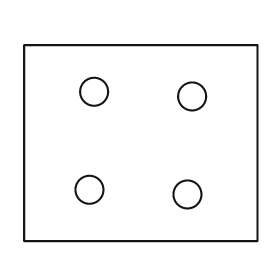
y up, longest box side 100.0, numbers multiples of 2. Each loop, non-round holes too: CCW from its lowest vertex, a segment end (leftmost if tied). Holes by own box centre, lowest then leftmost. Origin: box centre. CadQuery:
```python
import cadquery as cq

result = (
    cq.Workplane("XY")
    .moveTo(-50.0, -42.0)
    .lineTo(50.0, -42.0)
    .lineTo(50.0, 42.0)
    .lineTo(-50.0, 42.0)
    .close()
    .moveTo(20.0, -22.0)
    .circle(6.0)
    .moveTo(-22.0, -20.0)
    .circle(6.0)
    .moveTo(22.0, 20.0)
    .circle(6.0)
    .moveTo(-20.0, 22.0)
    .circle(6.0)
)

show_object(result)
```